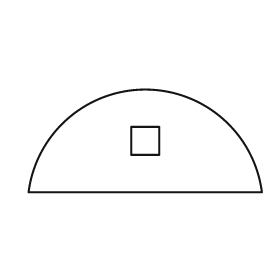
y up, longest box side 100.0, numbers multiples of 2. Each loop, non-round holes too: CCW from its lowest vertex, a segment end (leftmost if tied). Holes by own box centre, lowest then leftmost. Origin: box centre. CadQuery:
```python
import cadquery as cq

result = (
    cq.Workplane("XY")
    .moveTo(-50.0, -22.0)
    .lineTo(50.0, -22.0)
    .threePointArc((0.0, 22.0), (-50.0, -22.0))
    .close()
    .moveTo(-6.0, -6.0)
    .lineTo(6.0, -6.0)
    .lineTo(6.0, 6.0)
    .lineTo(-6.0, 6.0)
    .close()
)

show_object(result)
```